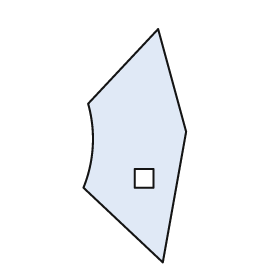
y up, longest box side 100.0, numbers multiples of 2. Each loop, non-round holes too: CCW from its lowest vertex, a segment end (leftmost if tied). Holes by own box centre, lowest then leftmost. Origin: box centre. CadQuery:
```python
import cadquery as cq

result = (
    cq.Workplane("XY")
    .moveTo(12.0, -50.0)
    .lineTo(22.0, 6.0)
    .lineTo(10.0, 50.0)
    .lineTo(-20.0, 18.0)
    .threePointArc((-18.0, 0.0), (-22.0, -18.0))
    .close()
    .moveTo(0.0, -18.0)
    .lineTo(8.0, -18.0)
    .lineTo(8.0, -10.0)
    .lineTo(0.0, -10.0)
    .close()
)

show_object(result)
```